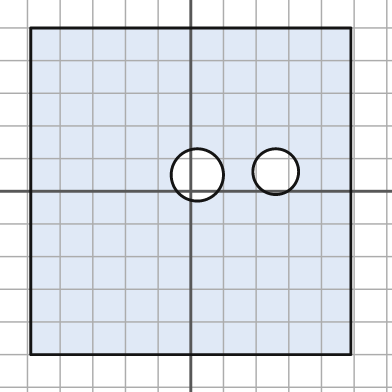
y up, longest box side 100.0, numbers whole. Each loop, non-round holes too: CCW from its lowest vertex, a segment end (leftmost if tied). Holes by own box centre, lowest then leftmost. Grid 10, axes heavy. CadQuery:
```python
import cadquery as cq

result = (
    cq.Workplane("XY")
    .moveTo(-49.0, -50.0)
    .lineTo(49.0, -50.0)
    .lineTo(49.0, 50.0)
    .lineTo(-49.0, 50.0)
    .close()
    .moveTo(2.0, 5.0)
    .circle(8.0)
    .moveTo(26.0, 6.0)
    .circle(7.0)
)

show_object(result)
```